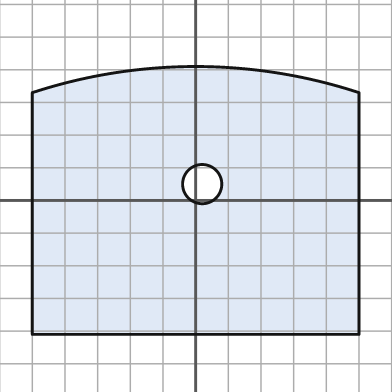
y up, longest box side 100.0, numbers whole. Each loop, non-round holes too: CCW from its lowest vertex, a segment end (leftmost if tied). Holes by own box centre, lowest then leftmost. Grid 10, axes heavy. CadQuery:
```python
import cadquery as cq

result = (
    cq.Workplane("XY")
    .moveTo(-50.0, -41.0)
    .lineTo(50.0, -41.0)
    .lineTo(50.0, 33.0)
    .threePointArc((0.0, 41.0), (-50.0, 33.0))
    .close()
    .moveTo(2.0, 5.0)
    .circle(6.0)
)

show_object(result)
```